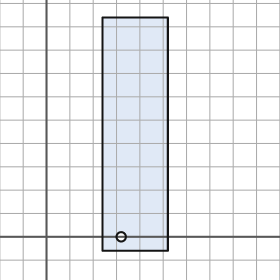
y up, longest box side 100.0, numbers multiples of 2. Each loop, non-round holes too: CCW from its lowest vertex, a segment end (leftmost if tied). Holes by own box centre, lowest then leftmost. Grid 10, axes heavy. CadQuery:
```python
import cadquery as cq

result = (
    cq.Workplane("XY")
    .moveTo(24.0, -6.0)
    .lineTo(52.0, -6.0)
    .lineTo(52.0, 94.0)
    .lineTo(24.0, 94.0)
    .close()
    .moveTo(32.0, 0.0)
    .circle(2.0)
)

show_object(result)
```